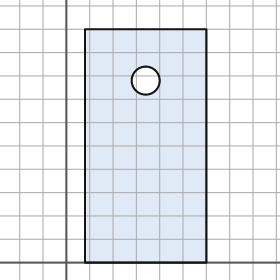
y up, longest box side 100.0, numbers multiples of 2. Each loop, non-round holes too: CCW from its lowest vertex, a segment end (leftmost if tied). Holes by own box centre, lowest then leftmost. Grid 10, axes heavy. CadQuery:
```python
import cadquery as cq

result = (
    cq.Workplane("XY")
    .moveTo(8.0, 0.0)
    .lineTo(60.0, 0.0)
    .lineTo(60.0, 100.0)
    .lineTo(8.0, 100.0)
    .close()
    .moveTo(34.0, 78.0)
    .circle(6.0)
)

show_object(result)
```